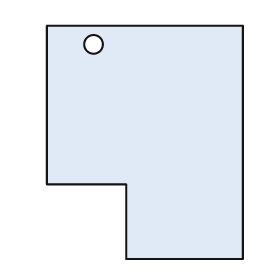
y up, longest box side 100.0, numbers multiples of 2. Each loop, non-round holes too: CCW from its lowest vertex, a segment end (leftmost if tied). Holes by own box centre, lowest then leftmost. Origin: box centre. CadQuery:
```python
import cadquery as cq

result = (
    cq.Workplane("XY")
    .moveTo(-8.0, -50.0)
    .lineTo(42.0, -50.0)
    .lineTo(42.0, 50.0)
    .lineTo(-42.0, 50.0)
    .lineTo(-42.0, -18.0)
    .lineTo(-8.0, -18.0)
    .close()
    .moveTo(-22.0, 42.0)
    .circle(4.0)
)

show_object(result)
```